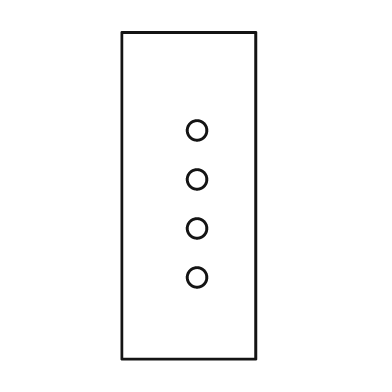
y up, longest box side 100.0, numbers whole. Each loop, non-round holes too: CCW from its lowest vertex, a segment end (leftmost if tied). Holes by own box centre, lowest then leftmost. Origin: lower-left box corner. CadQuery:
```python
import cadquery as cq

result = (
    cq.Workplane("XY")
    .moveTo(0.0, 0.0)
    .lineTo(41.0, 0.0)
    .lineTo(41.0, 100.0)
    .lineTo(0.0, 100.0)
    .close()
    .moveTo(23.0, 25.0)
    .circle(3.0)
    .moveTo(23.0, 40.0)
    .circle(3.0)
    .moveTo(23.0, 55.0)
    .circle(3.0)
    .moveTo(23.0, 70.0)
    .circle(3.0)
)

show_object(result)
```